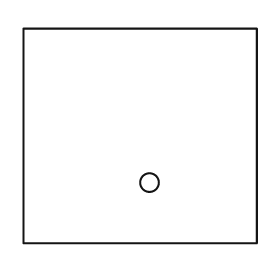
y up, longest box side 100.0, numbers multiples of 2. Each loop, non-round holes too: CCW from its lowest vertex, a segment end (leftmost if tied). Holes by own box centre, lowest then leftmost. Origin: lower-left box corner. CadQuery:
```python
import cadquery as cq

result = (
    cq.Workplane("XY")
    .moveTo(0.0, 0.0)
    .lineTo(100.0, 0.0)
    .lineTo(100.0, 92.0)
    .lineTo(0.0, 92.0)
    .close()
    .moveTo(54.0, 26.0)
    .circle(4.0)
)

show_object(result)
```